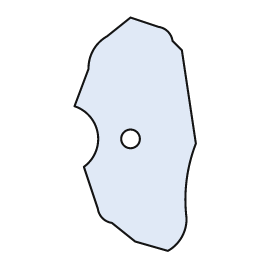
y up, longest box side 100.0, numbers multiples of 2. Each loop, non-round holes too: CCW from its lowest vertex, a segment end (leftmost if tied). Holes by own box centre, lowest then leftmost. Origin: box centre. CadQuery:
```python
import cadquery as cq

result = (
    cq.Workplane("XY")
    .moveTo(14.0, -50.0)
    .threePointArc((20.0, -44.0), (22.0, -36.0))
    .threePointArc((22.0, -20.0), (26.0, -4.0))
    .lineTo(20.0, 36.0)
    .lineTo(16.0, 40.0)
    .threePointArc((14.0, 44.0), (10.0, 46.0))
    .lineTo(-2.0, 50.0)
    .lineTo(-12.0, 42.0)
    .threePointArc((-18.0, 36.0), (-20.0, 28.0))
    .lineTo(-26.0, 12.0)
    .threePointArc((-16.0, 0.0), (-22.0, -14.0))
    .lineTo(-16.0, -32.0)
    .threePointArc((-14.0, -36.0), (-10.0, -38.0))
    .lineTo(0.0, -46.0)
    .close()
    .moveTo(-2.0, -2.0)
    .circle(4.0)
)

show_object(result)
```